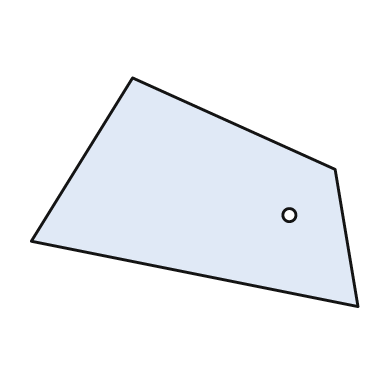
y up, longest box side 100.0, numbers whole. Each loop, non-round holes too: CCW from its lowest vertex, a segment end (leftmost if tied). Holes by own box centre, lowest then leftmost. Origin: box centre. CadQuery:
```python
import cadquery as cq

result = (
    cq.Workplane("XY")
    .moveTo(50.0, -35.0)
    .lineTo(43.0, 7.0)
    .lineTo(-19.0, 35.0)
    .lineTo(-50.0, -15.0)
    .close()
    .moveTo(29.0, -7.0)
    .circle(2.0)
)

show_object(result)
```